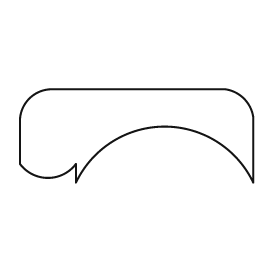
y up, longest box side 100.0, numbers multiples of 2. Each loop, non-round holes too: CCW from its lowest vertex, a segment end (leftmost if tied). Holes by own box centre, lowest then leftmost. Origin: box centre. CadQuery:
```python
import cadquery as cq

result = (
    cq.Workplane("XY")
    .moveTo(-26.0, -20.0)
    .threePointArc((12.0, 4.0), (50.0, -20.0))
    .lineTo(50.0, 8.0)
    .threePointArc((46.0, 16.0), (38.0, 20.0))
    .lineTo(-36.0, 20.0)
    .threePointArc((-46.0, 16.0), (-50.0, 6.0))
    .lineTo(-50.0, -12.0)
    .threePointArc((-38.0, -18.0), (-26.0, -12.0))
    .close()
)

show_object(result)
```